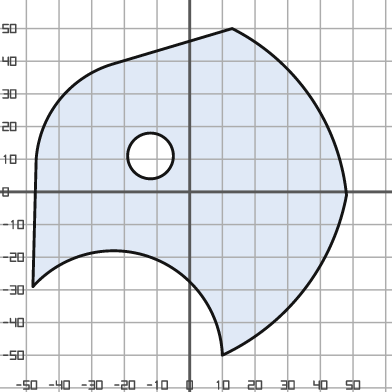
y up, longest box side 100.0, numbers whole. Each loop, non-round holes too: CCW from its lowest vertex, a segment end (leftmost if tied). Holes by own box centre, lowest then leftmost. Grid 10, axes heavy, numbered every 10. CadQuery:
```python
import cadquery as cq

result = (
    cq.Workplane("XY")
    .moveTo(10.0, -50.0)
    .threePointArc((35.0, -30.0), (48.0, -1.0))
    .threePointArc((37.0, 29.0), (13.0, 50.0))
    .lineTo(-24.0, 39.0)
    .threePointArc((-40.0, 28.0), (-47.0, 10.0))
    .lineTo(-48.0, -29.0)
    .threePointArc((-12.0, -20.0), (10.0, -50.0))
    .close()
    .moveTo(-12.0, 11.0)
    .circle(7.0)
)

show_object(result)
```